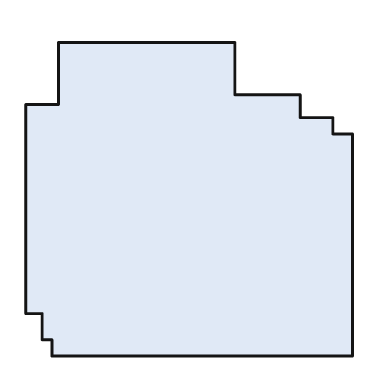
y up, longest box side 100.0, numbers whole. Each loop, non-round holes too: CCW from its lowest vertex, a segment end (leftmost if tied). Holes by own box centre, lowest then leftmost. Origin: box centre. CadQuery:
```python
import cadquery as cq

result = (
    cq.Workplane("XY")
    .moveTo(-42.0, -48.0)
    .lineTo(50.0, -48.0)
    .lineTo(50.0, 20.0)
    .lineTo(44.0, 20.0)
    .lineTo(44.0, 25.0)
    .lineTo(34.0, 25.0)
    .lineTo(34.0, 32.0)
    .lineTo(14.0, 32.0)
    .lineTo(14.0, 48.0)
    .lineTo(-40.0, 48.0)
    .lineTo(-40.0, 29.0)
    .lineTo(-50.0, 29.0)
    .lineTo(-50.0, -35.0)
    .lineTo(-45.0, -35.0)
    .lineTo(-45.0, -43.0)
    .lineTo(-42.0, -43.0)
    .close()
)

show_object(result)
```